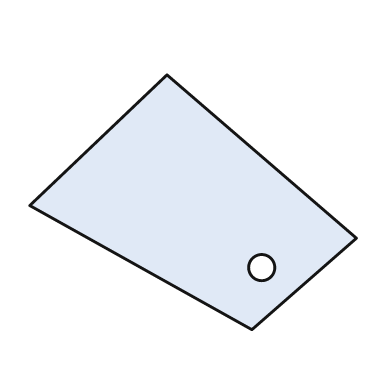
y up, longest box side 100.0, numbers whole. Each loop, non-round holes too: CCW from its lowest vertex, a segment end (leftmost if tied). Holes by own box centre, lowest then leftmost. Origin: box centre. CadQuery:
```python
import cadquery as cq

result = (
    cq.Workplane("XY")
    .moveTo(18.0, -39.0)
    .lineTo(50.0, -11.0)
    .lineTo(-8.0, 39.0)
    .lineTo(-50.0, -1.0)
    .close()
    .moveTo(21.0, -20.0)
    .circle(4.0)
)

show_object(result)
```